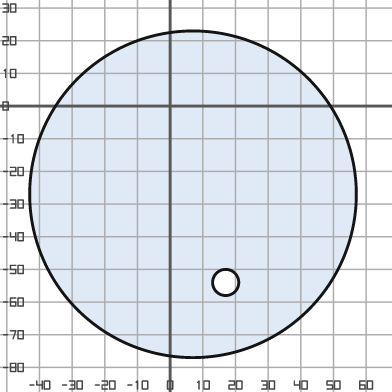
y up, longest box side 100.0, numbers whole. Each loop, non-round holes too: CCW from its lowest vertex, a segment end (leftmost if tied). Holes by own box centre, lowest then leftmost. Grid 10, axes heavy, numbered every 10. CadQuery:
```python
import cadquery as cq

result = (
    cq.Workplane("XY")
    .moveTo(7.0, -27.0)
    .circle(50.0)
    .moveTo(17.0, -54.0)
    .circle(4.0)
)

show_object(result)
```